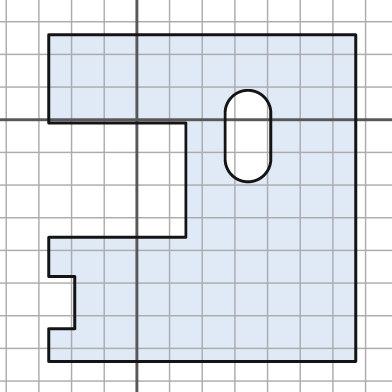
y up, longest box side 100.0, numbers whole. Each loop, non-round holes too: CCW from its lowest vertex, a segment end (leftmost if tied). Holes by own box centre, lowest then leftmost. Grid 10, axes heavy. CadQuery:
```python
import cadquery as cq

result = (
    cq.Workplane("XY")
    .moveTo(-27.0, -74.0)
    .lineTo(67.0, -74.0)
    .lineTo(67.0, 26.0)
    .lineTo(-27.0, 26.0)
    .lineTo(-27.0, -1.0)
    .lineTo(15.0, -1.0)
    .lineTo(15.0, -36.0)
    .lineTo(-27.0, -36.0)
    .lineTo(-27.0, -48.0)
    .lineTo(-19.0, -48.0)
    .lineTo(-19.0, -64.0)
    .lineTo(-27.0, -64.0)
    .close()
    .moveTo(27.0, -12.0)
    .threePointArc((34.0, -19.0), (41.0, -12.0))
    .lineTo(41.0, 2.0)
    .threePointArc((34.0, 9.0), (27.0, 2.0))
    .close()
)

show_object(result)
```